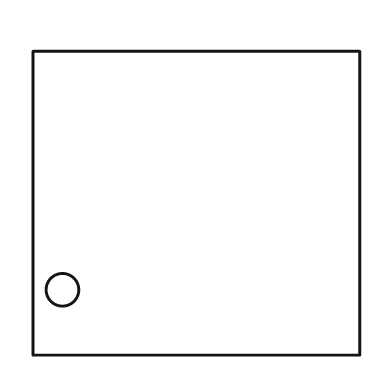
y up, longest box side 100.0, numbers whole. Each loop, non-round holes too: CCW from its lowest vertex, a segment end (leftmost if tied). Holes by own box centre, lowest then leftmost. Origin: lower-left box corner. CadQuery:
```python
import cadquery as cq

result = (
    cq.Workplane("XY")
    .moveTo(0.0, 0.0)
    .lineTo(100.0, 0.0)
    .lineTo(100.0, 93.0)
    .lineTo(0.0, 93.0)
    .close()
    .moveTo(9.0, 20.0)
    .circle(5.0)
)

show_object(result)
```